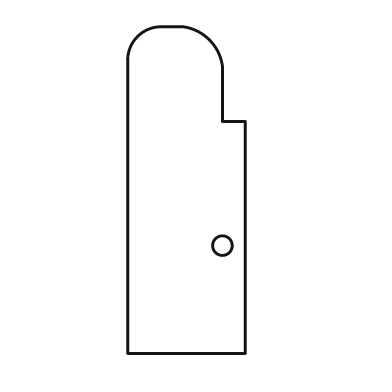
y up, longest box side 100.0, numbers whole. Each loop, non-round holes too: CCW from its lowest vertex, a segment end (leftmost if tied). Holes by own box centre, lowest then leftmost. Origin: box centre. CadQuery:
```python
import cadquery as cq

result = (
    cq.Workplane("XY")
    .moveTo(-18.0, -50.0)
    .lineTo(18.0, -50.0)
    .lineTo(18.0, 21.0)
    .lineTo(11.0, 21.0)
    .lineTo(11.0, 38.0)
    .threePointArc((7.0, 46.0), (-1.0, 50.0))
    .lineTo(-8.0, 50.0)
    .threePointArc((-15.0, 47.0), (-18.0, 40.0))
    .close()
    .moveTo(11.0, -17.0)
    .circle(3.0)
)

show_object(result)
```